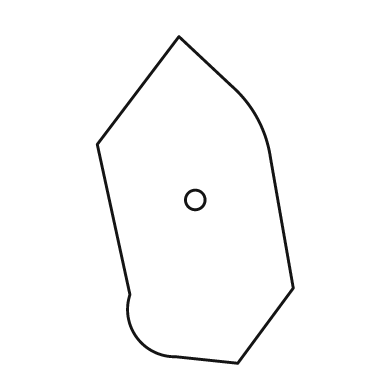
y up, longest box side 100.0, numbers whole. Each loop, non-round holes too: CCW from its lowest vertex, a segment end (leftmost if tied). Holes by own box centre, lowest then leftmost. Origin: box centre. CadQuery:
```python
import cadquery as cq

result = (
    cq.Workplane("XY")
    .moveTo(13.0, -50.0)
    .lineTo(30.0, -27.0)
    .lineTo(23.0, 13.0)
    .threePointArc((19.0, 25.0), (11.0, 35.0))
    .lineTo(-5.0, 50.0)
    .lineTo(-30.0, 17.0)
    .lineTo(-20.0, -29.0)
    .threePointArc((-18.0, -42.0), (-6.0, -48.0))
    .close()
    .moveTo(0.0, 0.0)
    .circle(3.0)
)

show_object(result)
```